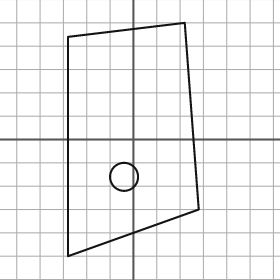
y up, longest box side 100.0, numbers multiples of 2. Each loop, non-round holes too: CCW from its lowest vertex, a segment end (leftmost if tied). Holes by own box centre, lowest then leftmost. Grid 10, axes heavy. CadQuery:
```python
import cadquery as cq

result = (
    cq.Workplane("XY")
    .moveTo(-28.0, -50.0)
    .lineTo(28.0, -30.0)
    .lineTo(22.0, 50.0)
    .lineTo(-28.0, 44.0)
    .close()
    .moveTo(-4.0, -16.0)
    .circle(6.0)
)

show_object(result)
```